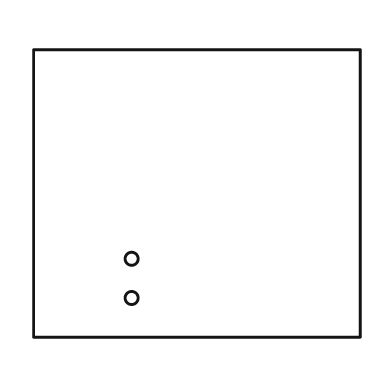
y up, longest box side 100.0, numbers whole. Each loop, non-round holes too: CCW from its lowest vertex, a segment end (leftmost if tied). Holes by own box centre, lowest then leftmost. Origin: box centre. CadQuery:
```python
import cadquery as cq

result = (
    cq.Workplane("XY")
    .moveTo(-50.0, -44.0)
    .lineTo(50.0, -44.0)
    .lineTo(50.0, 44.0)
    .lineTo(-50.0, 44.0)
    .close()
    .moveTo(-20.0, -32.0)
    .circle(2.0)
    .moveTo(-20.0, -20.0)
    .circle(2.0)
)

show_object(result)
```